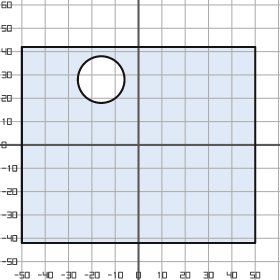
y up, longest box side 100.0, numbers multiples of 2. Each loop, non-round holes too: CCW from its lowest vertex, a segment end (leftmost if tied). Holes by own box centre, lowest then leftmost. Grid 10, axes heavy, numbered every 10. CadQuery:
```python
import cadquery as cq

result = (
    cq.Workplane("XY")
    .moveTo(-50.0, -42.0)
    .lineTo(50.0, -42.0)
    .lineTo(50.0, 42.0)
    .lineTo(-50.0, 42.0)
    .close()
    .moveTo(-16.0, 28.0)
    .circle(10.0)
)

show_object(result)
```